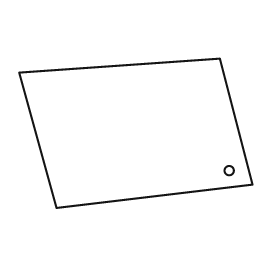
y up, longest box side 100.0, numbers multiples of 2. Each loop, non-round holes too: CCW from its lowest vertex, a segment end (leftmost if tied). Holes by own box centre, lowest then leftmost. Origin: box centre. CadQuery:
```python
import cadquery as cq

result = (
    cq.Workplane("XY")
    .moveTo(-34.0, -32.0)
    .lineTo(50.0, -22.0)
    .lineTo(36.0, 32.0)
    .lineTo(-50.0, 26.0)
    .close()
    .moveTo(40.0, -16.0)
    .circle(2.0)
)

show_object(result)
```